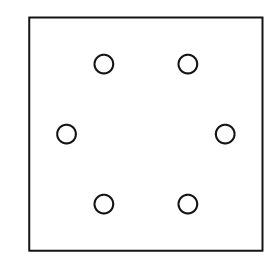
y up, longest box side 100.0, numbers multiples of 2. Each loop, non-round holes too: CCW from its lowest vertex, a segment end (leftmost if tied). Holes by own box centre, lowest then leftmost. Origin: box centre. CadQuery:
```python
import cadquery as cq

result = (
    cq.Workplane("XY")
    .moveTo(-50.0, -50.0)
    .lineTo(50.0, -50.0)
    .lineTo(50.0, 50.0)
    .lineTo(-50.0, 50.0)
    .close()
    .moveTo(-18.0, -30.0)
    .circle(4.0)
    .moveTo(18.0, -30.0)
    .circle(4.0)
    .moveTo(-34.0, 0.0)
    .circle(4.0)
    .moveTo(34.0, 0.0)
    .circle(4.0)
    .moveTo(-18.0, 30.0)
    .circle(4.0)
    .moveTo(18.0, 30.0)
    .circle(4.0)
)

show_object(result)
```